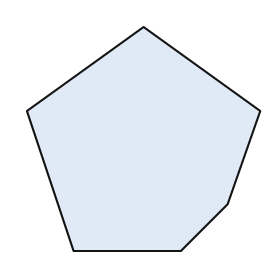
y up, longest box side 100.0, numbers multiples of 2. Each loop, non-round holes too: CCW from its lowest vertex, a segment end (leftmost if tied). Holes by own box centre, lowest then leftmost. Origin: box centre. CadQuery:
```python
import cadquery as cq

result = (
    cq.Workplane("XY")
    .moveTo(-30.0, -48.0)
    .lineTo(16.0, -48.0)
    .lineTo(36.0, -28.0)
    .lineTo(50.0, 12.0)
    .lineTo(0.0, 48.0)
    .lineTo(-50.0, 12.0)
    .close()
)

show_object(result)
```